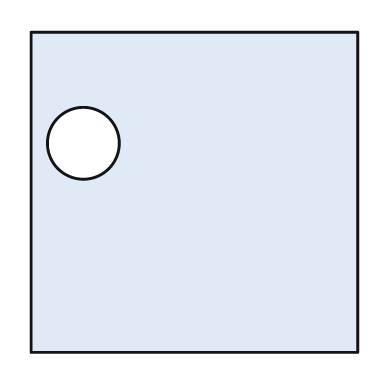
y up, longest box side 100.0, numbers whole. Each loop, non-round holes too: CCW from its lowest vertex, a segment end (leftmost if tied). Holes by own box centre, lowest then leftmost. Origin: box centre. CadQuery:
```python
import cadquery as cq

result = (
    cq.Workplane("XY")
    .moveTo(-50.0, -49.0)
    .lineTo(50.0, -49.0)
    .lineTo(50.0, 49.0)
    .lineTo(-50.0, 49.0)
    .close()
    .moveTo(-34.0, 15.0)
    .circle(11.0)
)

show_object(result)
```